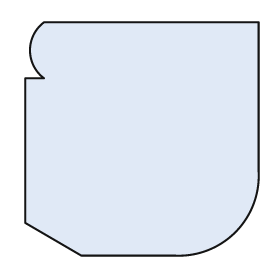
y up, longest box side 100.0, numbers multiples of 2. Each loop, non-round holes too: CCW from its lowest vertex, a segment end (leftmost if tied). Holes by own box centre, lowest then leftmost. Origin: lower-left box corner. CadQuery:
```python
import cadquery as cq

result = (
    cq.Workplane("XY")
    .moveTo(24.0, 0.0)
    .lineTo(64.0, 0.0)
    .threePointArc((90.0, 10.0), (100.0, 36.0))
    .lineTo(100.0, 100.0)
    .lineTo(8.0, 100.0)
    .threePointArc((2.0, 88.0), (8.0, 76.0))
    .lineTo(0.0, 76.0)
    .lineTo(0.0, 14.0)
    .close()
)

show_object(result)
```